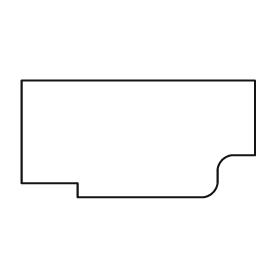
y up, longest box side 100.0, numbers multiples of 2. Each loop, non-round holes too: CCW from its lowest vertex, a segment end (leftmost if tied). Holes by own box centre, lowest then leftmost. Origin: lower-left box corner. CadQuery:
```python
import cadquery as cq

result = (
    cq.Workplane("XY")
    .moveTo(24.0, 0.0)
    .lineTo(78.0, 0.0)
    .threePointArc((82.0, 2.0), (84.0, 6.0))
    .lineTo(84.0, 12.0)
    .threePointArc((86.0, 16.0), (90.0, 18.0))
    .lineTo(100.0, 18.0)
    .lineTo(100.0, 50.0)
    .lineTo(0.0, 50.0)
    .lineTo(0.0, 6.0)
    .lineTo(24.0, 6.0)
    .close()
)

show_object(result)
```